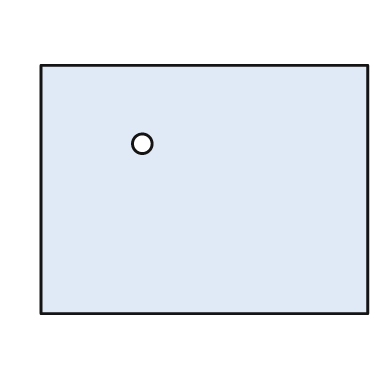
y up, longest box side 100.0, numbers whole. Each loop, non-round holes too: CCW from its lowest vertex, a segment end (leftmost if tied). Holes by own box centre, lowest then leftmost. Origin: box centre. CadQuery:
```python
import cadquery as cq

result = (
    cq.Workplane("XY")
    .moveTo(-50.0, -38.0)
    .lineTo(50.0, -38.0)
    .lineTo(50.0, 38.0)
    .lineTo(-50.0, 38.0)
    .close()
    .moveTo(-19.0, 14.0)
    .circle(3.0)
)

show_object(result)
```